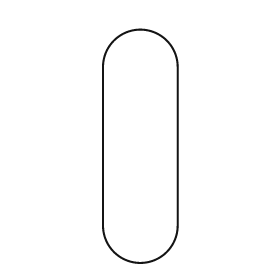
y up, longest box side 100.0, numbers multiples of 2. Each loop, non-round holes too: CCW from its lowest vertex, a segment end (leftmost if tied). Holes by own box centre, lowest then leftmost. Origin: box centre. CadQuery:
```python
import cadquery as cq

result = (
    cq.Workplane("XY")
    .moveTo(-16.0, -34.0)
    .threePointArc((0.0, -50.0), (16.0, -34.0))
    .lineTo(16.0, 34.0)
    .threePointArc((0.0, 50.0), (-16.0, 34.0))
    .close()
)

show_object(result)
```